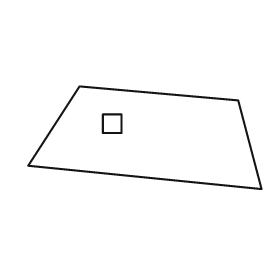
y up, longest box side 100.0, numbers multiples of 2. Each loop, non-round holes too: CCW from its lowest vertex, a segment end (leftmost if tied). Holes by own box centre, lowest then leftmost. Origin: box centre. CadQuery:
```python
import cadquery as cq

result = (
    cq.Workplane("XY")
    .moveTo(50.0, -22.0)
    .lineTo(40.0, 16.0)
    .lineTo(-28.0, 22.0)
    .lineTo(-50.0, -12.0)
    .close()
    .moveTo(-18.0, 2.0)
    .lineTo(-10.0, 2.0)
    .lineTo(-10.0, 10.0)
    .lineTo(-18.0, 10.0)
    .close()
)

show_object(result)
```